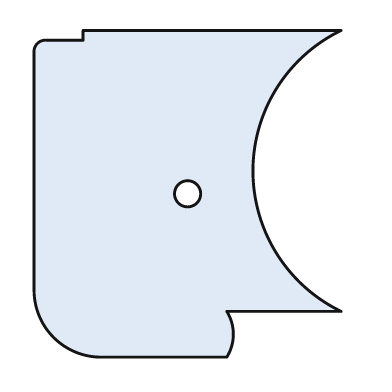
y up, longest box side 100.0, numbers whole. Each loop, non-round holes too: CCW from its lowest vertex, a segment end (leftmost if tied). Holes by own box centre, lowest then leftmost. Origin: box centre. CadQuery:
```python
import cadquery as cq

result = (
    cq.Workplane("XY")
    .moveTo(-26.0, -50.0)
    .lineTo(12.0, -50.0)
    .threePointArc((14.0, -43.0), (12.0, -36.0))
    .lineTo(47.0, -36.0)
    .threePointArc((20.0, 7.0), (47.0, 50.0))
    .lineTo(-32.0, 50.0)
    .lineTo(-32.0, 47.0)
    .lineTo(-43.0, 47.0)
    .threePointArc((-46.0, 46.0), (-47.0, 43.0))
    .lineTo(-47.0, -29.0)
    .threePointArc((-41.0, -44.0), (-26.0, -50.0))
    .close()
    .moveTo(0.0, 0.0)
    .circle(4.0)
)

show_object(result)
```